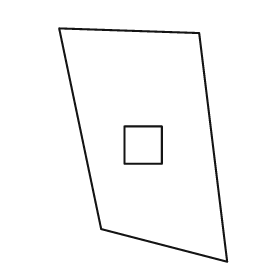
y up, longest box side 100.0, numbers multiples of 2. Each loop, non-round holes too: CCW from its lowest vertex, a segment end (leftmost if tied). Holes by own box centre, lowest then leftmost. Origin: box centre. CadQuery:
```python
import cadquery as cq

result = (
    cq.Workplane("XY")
    .moveTo(36.0, -50.0)
    .lineTo(24.0, 48.0)
    .lineTo(-36.0, 50.0)
    .lineTo(-18.0, -36.0)
    .close()
    .moveTo(-8.0, -8.0)
    .lineTo(8.0, -8.0)
    .lineTo(8.0, 8.0)
    .lineTo(-8.0, 8.0)
    .close()
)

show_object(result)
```